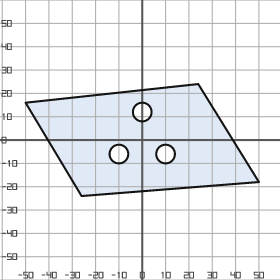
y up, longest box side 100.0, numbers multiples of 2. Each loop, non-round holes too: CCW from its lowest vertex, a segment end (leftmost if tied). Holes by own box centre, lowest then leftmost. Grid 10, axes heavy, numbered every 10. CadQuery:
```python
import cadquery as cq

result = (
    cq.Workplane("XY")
    .moveTo(-26.0, -24.0)
    .lineTo(50.0, -18.0)
    .lineTo(24.0, 24.0)
    .lineTo(-50.0, 16.0)
    .close()
    .moveTo(-10.0, -6.0)
    .circle(4.0)
    .moveTo(10.0, -6.0)
    .circle(4.0)
    .moveTo(0.0, 12.0)
    .circle(4.0)
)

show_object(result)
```